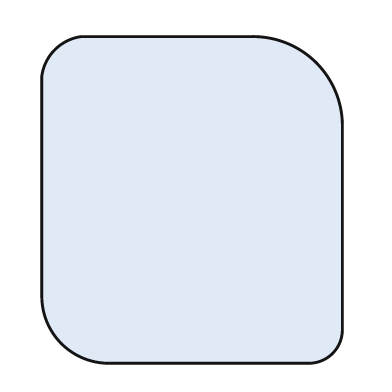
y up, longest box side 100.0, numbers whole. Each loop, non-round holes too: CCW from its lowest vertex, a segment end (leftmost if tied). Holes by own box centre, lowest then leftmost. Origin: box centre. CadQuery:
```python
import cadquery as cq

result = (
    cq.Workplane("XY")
    .moveTo(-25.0, -50.0)
    .lineTo(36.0, -50.0)
    .threePointArc((43.0, -47.0), (46.0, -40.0))
    .lineTo(46.0, 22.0)
    .threePointArc((38.0, 42.0), (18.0, 50.0))
    .lineTo(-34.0, 50.0)
    .threePointArc((-42.0, 46.0), (-46.0, 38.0))
    .lineTo(-46.0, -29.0)
    .threePointArc((-40.0, -44.0), (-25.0, -50.0))
    .close()
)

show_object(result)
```